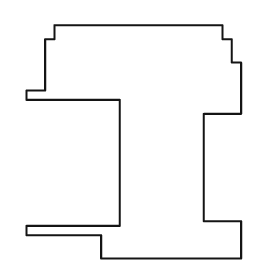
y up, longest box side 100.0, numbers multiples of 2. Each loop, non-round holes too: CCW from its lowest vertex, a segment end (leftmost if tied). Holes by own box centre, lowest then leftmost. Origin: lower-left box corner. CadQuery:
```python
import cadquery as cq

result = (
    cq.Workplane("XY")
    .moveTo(32.0, 0.0)
    .lineTo(92.0, 0.0)
    .lineTo(92.0, 16.0)
    .lineTo(76.0, 16.0)
    .lineTo(76.0, 62.0)
    .lineTo(92.0, 62.0)
    .lineTo(92.0, 84.0)
    .lineTo(88.0, 84.0)
    .lineTo(88.0, 94.0)
    .lineTo(84.0, 94.0)
    .lineTo(84.0, 100.0)
    .lineTo(12.0, 100.0)
    .lineTo(12.0, 94.0)
    .lineTo(8.0, 94.0)
    .lineTo(8.0, 72.0)
    .lineTo(0.0, 72.0)
    .lineTo(0.0, 68.0)
    .lineTo(40.0, 68.0)
    .lineTo(40.0, 14.0)
    .lineTo(0.0, 14.0)
    .lineTo(0.0, 10.0)
    .lineTo(32.0, 10.0)
    .close()
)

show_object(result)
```